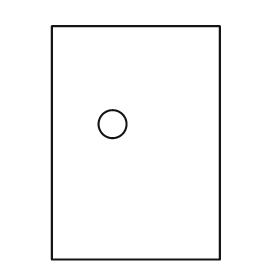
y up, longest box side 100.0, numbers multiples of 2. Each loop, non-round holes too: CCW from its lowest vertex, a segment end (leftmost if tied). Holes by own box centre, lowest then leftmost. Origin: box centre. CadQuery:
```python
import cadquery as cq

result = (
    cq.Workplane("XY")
    .moveTo(-36.0, -50.0)
    .lineTo(36.0, -50.0)
    .lineTo(36.0, 50.0)
    .lineTo(-36.0, 50.0)
    .close()
    .moveTo(-10.0, 8.0)
    .circle(6.0)
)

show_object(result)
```